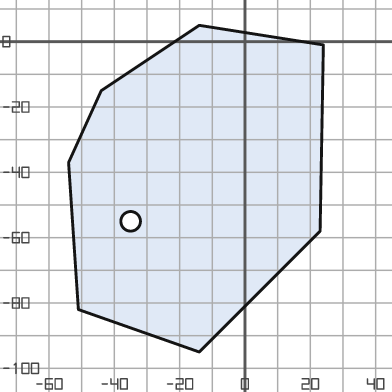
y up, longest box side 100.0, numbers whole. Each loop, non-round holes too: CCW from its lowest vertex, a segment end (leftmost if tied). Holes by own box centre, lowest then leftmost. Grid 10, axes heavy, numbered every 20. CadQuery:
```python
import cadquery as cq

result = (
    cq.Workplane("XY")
    .moveTo(-14.0, -95.0)
    .lineTo(23.0, -58.0)
    .lineTo(24.0, -1.0)
    .lineTo(-14.0, 5.0)
    .lineTo(-44.0, -15.0)
    .lineTo(-54.0, -37.0)
    .lineTo(-51.0, -82.0)
    .close()
    .moveTo(-35.0, -55.0)
    .circle(3.0)
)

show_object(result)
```